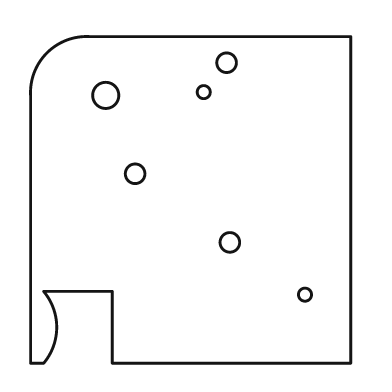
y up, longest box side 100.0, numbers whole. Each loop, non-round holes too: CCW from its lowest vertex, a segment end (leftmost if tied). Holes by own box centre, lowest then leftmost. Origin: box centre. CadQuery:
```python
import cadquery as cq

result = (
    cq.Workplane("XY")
    .moveTo(-49.0, -50.0)
    .lineTo(-45.0, -50.0)
    .threePointArc((-41.0, -39.0), (-45.0, -28.0))
    .lineTo(-24.0, -28.0)
    .lineTo(-24.0, -50.0)
    .lineTo(49.0, -50.0)
    .lineTo(49.0, 50.0)
    .lineTo(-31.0, 50.0)
    .threePointArc((-44.0, 45.0), (-49.0, 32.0))
    .close()
    .moveTo(35.0, -29.0)
    .circle(2.0)
    .moveTo(12.0, -13.0)
    .circle(3.0)
    .moveTo(-17.0, 8.0)
    .circle(3.0)
    .moveTo(-26.0, 32.0)
    .circle(4.0)
    .moveTo(4.0, 33.0)
    .circle(2.0)
    .moveTo(11.0, 42.0)
    .circle(3.0)
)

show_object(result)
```